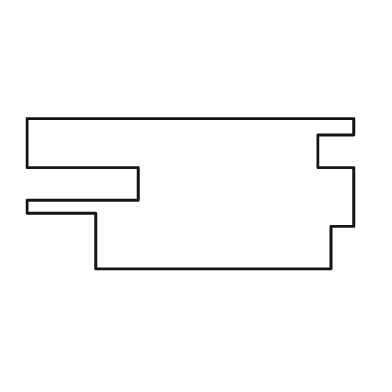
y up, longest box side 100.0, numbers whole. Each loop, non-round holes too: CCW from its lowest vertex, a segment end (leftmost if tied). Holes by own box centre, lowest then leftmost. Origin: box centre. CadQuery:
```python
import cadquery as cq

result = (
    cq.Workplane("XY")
    .moveTo(-29.0, -23.0)
    .lineTo(43.0, -23.0)
    .lineTo(43.0, -10.0)
    .lineTo(50.0, -10.0)
    .lineTo(50.0, 8.0)
    .lineTo(39.0, 8.0)
    .lineTo(39.0, 18.0)
    .lineTo(50.0, 18.0)
    .lineTo(50.0, 23.0)
    .lineTo(-50.0, 23.0)
    .lineTo(-50.0, 8.0)
    .lineTo(-16.0, 8.0)
    .lineTo(-16.0, -2.0)
    .lineTo(-50.0, -2.0)
    .lineTo(-50.0, -6.0)
    .lineTo(-29.0, -6.0)
    .close()
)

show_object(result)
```